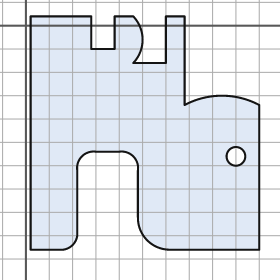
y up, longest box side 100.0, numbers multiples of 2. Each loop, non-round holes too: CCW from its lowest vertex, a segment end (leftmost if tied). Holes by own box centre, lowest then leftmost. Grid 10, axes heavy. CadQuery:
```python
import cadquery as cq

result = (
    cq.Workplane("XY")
    .moveTo(2.0, -96.0)
    .lineTo(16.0, -96.0)
    .threePointArc((20.0, -94.0), (22.0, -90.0))
    .lineTo(22.0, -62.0)
    .threePointArc((24.0, -56.0), (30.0, -54.0))
    .lineTo(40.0, -54.0)
    .threePointArc((46.0, -56.0), (48.0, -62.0))
    .lineTo(48.0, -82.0)
    .threePointArc((52.0, -92.0), (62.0, -96.0))
    .lineTo(100.0, -96.0)
    .lineTo(100.0, -34.0)
    .threePointArc((84.0, -30.0), (68.0, -34.0))
    .lineTo(68.0, 4.0)
    .lineTo(60.0, 4.0)
    .lineTo(60.0, -16.0)
    .lineTo(46.0, -16.0)
    .threePointArc((50.0, -6.0), (46.0, 4.0))
    .lineTo(38.0, 4.0)
    .lineTo(38.0, -10.0)
    .lineTo(28.0, -10.0)
    .lineTo(28.0, 4.0)
    .lineTo(2.0, 4.0)
    .close()
    .moveTo(90.0, -56.0)
    .circle(4.0)
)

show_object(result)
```